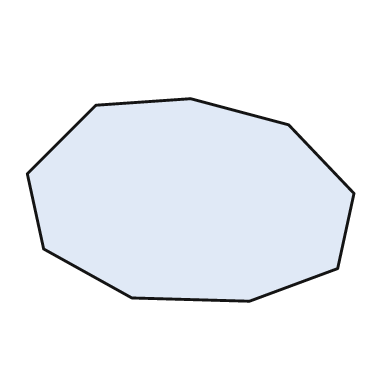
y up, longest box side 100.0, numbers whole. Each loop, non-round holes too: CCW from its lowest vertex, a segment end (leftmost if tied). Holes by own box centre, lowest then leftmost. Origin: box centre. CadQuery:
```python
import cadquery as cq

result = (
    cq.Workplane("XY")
    .moveTo(18.0, -31.0)
    .lineTo(45.0, -21.0)
    .lineTo(50.0, 2.0)
    .lineTo(30.0, 23.0)
    .lineTo(0.0, 31.0)
    .lineTo(-29.0, 29.0)
    .lineTo(-50.0, 8.0)
    .lineTo(-45.0, -15.0)
    .lineTo(-18.0, -30.0)
    .close()
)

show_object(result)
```